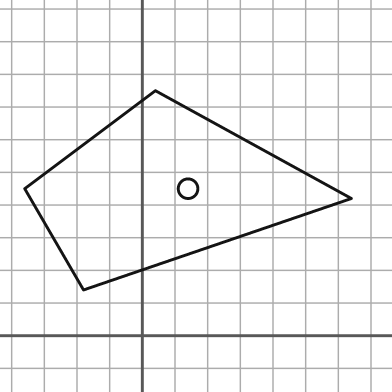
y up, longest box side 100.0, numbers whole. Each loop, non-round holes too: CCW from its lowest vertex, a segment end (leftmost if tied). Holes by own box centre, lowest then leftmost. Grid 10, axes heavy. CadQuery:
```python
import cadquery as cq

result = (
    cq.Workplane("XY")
    .moveTo(-18.0, 14.0)
    .lineTo(64.0, 42.0)
    .lineTo(4.0, 75.0)
    .lineTo(-36.0, 45.0)
    .close()
    .moveTo(14.0, 45.0)
    .circle(3.0)
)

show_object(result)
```